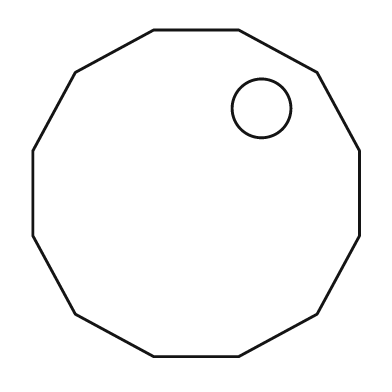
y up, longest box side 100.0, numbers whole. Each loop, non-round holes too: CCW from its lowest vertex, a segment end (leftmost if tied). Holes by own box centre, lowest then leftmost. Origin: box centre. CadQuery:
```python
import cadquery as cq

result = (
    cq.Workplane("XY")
    .moveTo(-13.0, -50.0)
    .lineTo(13.0, -50.0)
    .lineTo(37.0, -37.0)
    .lineTo(50.0, -13.0)
    .lineTo(50.0, 13.0)
    .lineTo(37.0, 37.0)
    .lineTo(13.0, 50.0)
    .lineTo(-13.0, 50.0)
    .lineTo(-37.0, 37.0)
    .lineTo(-50.0, 13.0)
    .lineTo(-50.0, -13.0)
    .lineTo(-37.0, -37.0)
    .close()
    .moveTo(20.0, 26.0)
    .circle(9.0)
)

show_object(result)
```